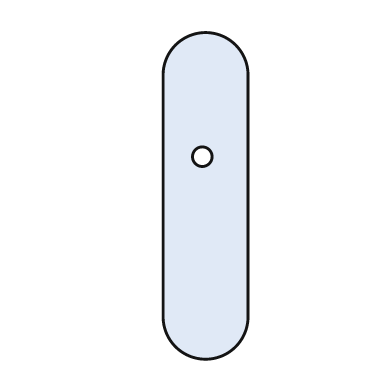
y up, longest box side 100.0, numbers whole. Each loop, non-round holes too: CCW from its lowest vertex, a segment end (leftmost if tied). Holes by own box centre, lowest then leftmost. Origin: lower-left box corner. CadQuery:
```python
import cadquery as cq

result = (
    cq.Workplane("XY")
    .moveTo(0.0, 13.0)
    .threePointArc((13.0, 0.0), (26.0, 13.0))
    .lineTo(26.0, 87.0)
    .threePointArc((13.0, 100.0), (0.0, 87.0))
    .close()
    .moveTo(12.0, 62.0)
    .circle(3.0)
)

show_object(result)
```